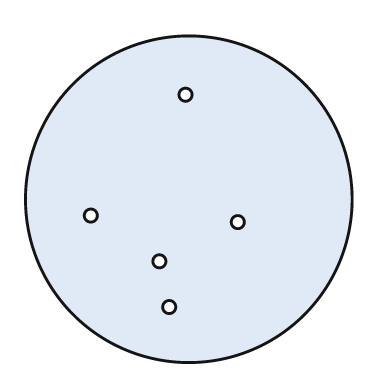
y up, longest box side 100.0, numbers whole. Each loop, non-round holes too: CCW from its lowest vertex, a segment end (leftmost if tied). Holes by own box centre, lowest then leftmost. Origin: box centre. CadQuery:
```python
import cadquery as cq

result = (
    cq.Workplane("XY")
    .moveTo(0.0, 0.0)
    .circle(50.0)
    .moveTo(-6.0, -33.0)
    .circle(2.0)
    .moveTo(-9.0, -19.0)
    .circle(2.0)
    .moveTo(15.0, -7.0)
    .circle(2.0)
    .moveTo(-30.0, -5.0)
    .circle(2.0)
    .moveTo(-1.0, 32.0)
    .circle(2.0)
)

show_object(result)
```